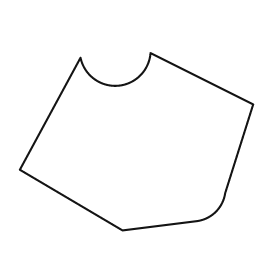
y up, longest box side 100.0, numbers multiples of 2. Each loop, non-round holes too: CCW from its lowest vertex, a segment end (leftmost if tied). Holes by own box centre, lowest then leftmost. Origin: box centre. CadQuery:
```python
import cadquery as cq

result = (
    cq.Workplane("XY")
    .moveTo(-6.0, -38.0)
    .lineTo(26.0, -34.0)
    .threePointArc((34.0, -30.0), (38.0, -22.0))
    .lineTo(50.0, 16.0)
    .lineTo(6.0, 38.0)
    .threePointArc((-8.0, 24.0), (-24.0, 36.0))
    .lineTo(-50.0, -12.0)
    .close()
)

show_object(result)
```